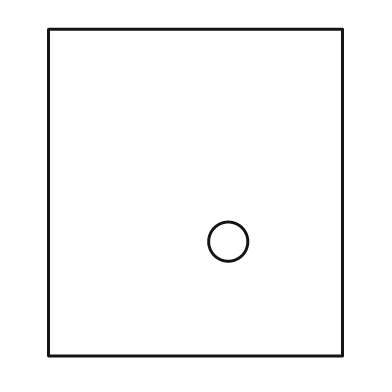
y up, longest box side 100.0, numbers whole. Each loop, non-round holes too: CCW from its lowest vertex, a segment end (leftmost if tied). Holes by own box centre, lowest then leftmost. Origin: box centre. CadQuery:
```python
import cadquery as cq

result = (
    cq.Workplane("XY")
    .moveTo(-45.0, -50.0)
    .lineTo(45.0, -50.0)
    .lineTo(45.0, 50.0)
    .lineTo(-45.0, 50.0)
    .close()
    .moveTo(10.0, -15.0)
    .circle(6.0)
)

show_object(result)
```